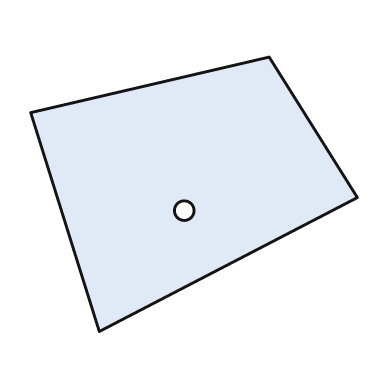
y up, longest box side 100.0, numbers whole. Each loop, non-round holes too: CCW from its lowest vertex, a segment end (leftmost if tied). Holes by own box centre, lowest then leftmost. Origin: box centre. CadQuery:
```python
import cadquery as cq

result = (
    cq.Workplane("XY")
    .moveTo(-29.0, -42.0)
    .lineTo(50.0, -1.0)
    .lineTo(23.0, 42.0)
    .lineTo(-50.0, 25.0)
    .close()
    .moveTo(-3.0, -5.0)
    .circle(3.0)
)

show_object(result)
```